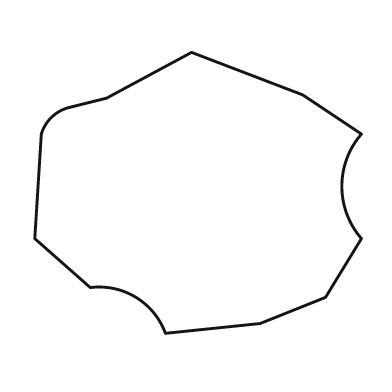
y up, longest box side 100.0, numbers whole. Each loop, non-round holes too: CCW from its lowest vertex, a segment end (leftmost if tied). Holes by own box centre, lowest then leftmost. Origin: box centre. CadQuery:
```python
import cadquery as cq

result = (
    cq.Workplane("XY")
    .moveTo(-10.0, -43.0)
    .lineTo(19.0, -40.0)
    .lineTo(39.0, -32.0)
    .lineTo(50.0, -14.0)
    .threePointArc((44.0, 2.0), (50.0, 18.0))
    .lineTo(32.0, 30.0)
    .lineTo(-2.0, 43.0)
    .lineTo(-28.0, 29.0)
    .lineTo(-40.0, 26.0)
    .threePointArc((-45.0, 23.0), (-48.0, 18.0))
    .lineTo(-50.0, -14.0)
    .lineTo(-33.0, -29.0)
    .threePointArc((-19.0, -32.0), (-10.0, -43.0))
    .close()
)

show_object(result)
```